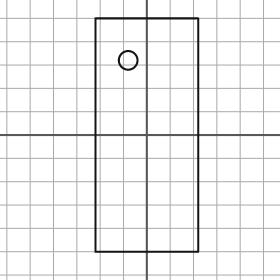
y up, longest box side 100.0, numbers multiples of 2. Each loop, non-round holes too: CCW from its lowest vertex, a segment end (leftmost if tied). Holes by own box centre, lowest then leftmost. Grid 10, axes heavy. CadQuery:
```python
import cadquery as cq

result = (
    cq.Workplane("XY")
    .moveTo(-22.0, -50.0)
    .lineTo(22.0, -50.0)
    .lineTo(22.0, 50.0)
    .lineTo(-22.0, 50.0)
    .close()
    .moveTo(-8.0, 32.0)
    .circle(4.0)
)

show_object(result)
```